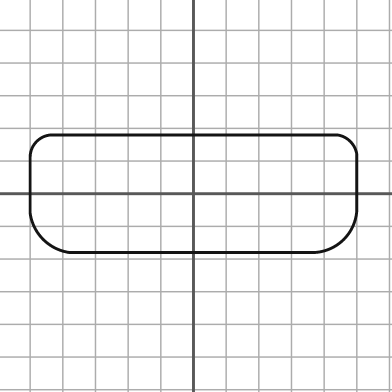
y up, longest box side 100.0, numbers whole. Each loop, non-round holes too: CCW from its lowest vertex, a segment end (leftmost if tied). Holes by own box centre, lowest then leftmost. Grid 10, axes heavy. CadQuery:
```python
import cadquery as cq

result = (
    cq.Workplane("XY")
    .moveTo(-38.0, -18.0)
    .lineTo(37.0, -18.0)
    .threePointArc((46.0, -14.0), (50.0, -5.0))
    .lineTo(50.0, 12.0)
    .threePointArc((48.0, 16.0), (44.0, 18.0))
    .lineTo(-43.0, 18.0)
    .threePointArc((-48.0, 16.0), (-50.0, 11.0))
    .lineTo(-50.0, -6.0)
    .threePointArc((-46.0, -14.0), (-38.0, -18.0))
    .close()
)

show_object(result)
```